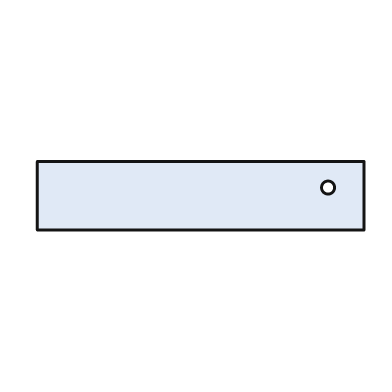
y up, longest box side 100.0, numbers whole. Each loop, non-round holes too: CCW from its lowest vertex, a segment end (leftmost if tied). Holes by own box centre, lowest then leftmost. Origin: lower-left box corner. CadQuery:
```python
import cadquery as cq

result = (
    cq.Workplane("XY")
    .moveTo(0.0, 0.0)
    .lineTo(100.0, 0.0)
    .lineTo(100.0, 21.0)
    .lineTo(0.0, 21.0)
    .close()
    .moveTo(89.0, 13.0)
    .circle(2.0)
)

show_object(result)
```